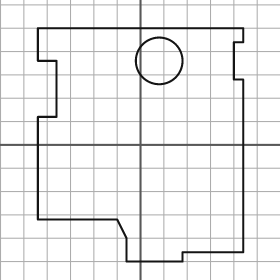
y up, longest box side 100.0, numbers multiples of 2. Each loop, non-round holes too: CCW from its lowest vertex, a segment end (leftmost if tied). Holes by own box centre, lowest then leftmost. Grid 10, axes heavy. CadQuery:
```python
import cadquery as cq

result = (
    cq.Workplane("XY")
    .moveTo(-6.0, -50.0)
    .lineTo(18.0, -50.0)
    .lineTo(18.0, -46.0)
    .lineTo(44.0, -46.0)
    .lineTo(44.0, 28.0)
    .lineTo(40.0, 28.0)
    .lineTo(40.0, 44.0)
    .lineTo(44.0, 44.0)
    .lineTo(44.0, 50.0)
    .lineTo(-44.0, 50.0)
    .lineTo(-44.0, 36.0)
    .lineTo(-36.0, 36.0)
    .lineTo(-36.0, 12.0)
    .lineTo(-44.0, 12.0)
    .lineTo(-44.0, -32.0)
    .lineTo(-10.0, -32.0)
    .lineTo(-6.0, -40.0)
    .close()
    .moveTo(8.0, 36.0)
    .circle(10.0)
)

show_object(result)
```